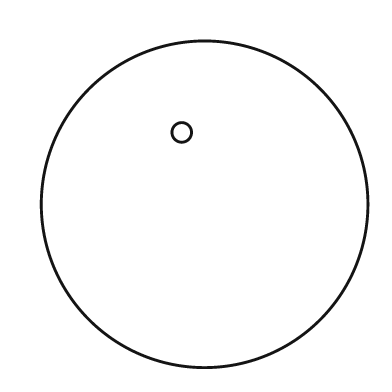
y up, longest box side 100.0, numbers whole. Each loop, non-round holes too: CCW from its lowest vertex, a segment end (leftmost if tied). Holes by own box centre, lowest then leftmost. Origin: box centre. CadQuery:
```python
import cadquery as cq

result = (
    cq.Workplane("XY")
    .moveTo(0.0, 0.0)
    .circle(50.0)
    .moveTo(-7.0, 22.0)
    .circle(3.0)
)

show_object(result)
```